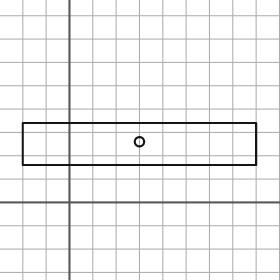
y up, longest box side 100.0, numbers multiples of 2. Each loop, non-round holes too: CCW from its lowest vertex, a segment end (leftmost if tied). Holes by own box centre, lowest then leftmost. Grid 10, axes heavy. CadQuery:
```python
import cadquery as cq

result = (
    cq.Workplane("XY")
    .moveTo(-20.0, 16.0)
    .lineTo(80.0, 16.0)
    .lineTo(80.0, 34.0)
    .lineTo(-20.0, 34.0)
    .close()
    .moveTo(30.0, 26.0)
    .circle(2.0)
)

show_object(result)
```